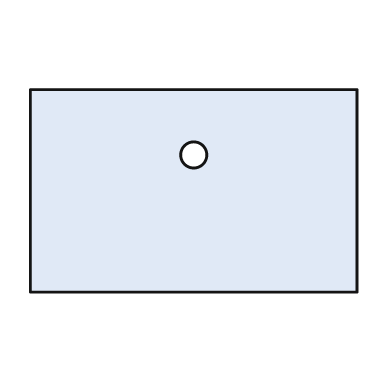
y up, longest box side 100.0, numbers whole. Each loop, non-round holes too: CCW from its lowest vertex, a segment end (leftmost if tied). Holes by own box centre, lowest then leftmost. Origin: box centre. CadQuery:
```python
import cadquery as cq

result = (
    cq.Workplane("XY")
    .moveTo(-50.0, -31.0)
    .lineTo(50.0, -31.0)
    .lineTo(50.0, 31.0)
    .lineTo(-50.0, 31.0)
    .close()
    .moveTo(0.0, 11.0)
    .circle(4.0)
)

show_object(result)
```